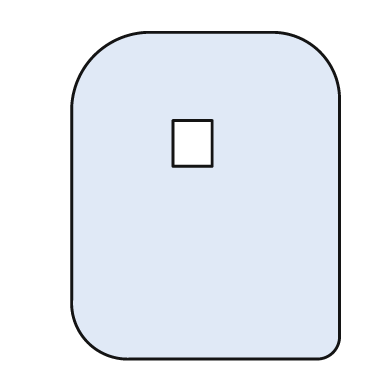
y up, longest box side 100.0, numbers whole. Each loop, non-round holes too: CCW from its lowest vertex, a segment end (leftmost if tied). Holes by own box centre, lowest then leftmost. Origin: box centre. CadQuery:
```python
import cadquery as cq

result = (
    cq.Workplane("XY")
    .moveTo(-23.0, -50.0)
    .lineTo(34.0, -50.0)
    .threePointArc((39.0, -48.0), (41.0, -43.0))
    .lineTo(41.0, 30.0)
    .threePointArc((35.0, 44.0), (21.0, 50.0))
    .lineTo(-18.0, 50.0)
    .threePointArc((-34.0, 43.0), (-41.0, 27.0))
    .lineTo(-41.0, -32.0)
    .threePointArc((-36.0, -45.0), (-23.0, -50.0))
    .close()
    .moveTo(-10.0, 9.0)
    .lineTo(2.0, 9.0)
    .lineTo(2.0, 23.0)
    .lineTo(-10.0, 23.0)
    .close()
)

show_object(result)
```